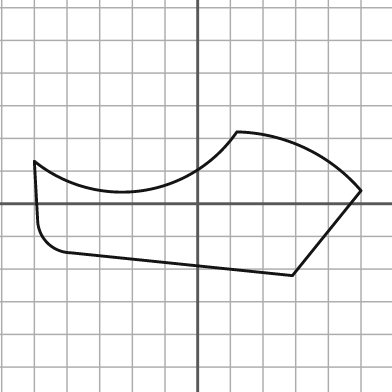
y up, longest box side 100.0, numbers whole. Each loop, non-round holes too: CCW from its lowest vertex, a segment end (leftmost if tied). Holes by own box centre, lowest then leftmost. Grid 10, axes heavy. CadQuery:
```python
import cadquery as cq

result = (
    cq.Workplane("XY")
    .moveTo(29.0, -22.0)
    .lineTo(50.0, 4.0)
    .threePointArc((33.0, 17.0), (12.0, 22.0))
    .threePointArc((-17.0, 4.0), (-50.0, 13.0))
    .lineTo(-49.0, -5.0)
    .threePointArc((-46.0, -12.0), (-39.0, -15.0))
    .close()
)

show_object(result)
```